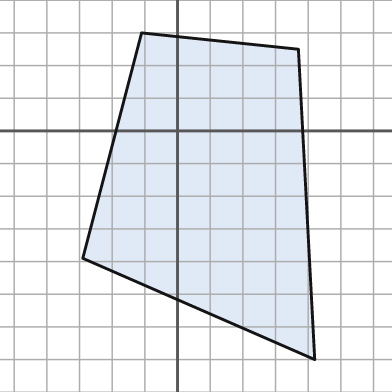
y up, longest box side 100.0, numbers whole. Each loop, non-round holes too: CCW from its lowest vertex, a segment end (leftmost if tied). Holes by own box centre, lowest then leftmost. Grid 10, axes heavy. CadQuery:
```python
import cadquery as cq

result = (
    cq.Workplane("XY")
    .moveTo(42.0, -70.0)
    .lineTo(37.0, 25.0)
    .lineTo(-11.0, 30.0)
    .lineTo(-29.0, -39.0)
    .close()
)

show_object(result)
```